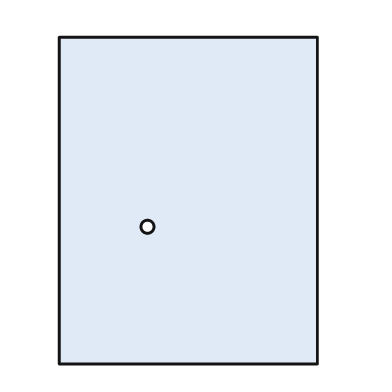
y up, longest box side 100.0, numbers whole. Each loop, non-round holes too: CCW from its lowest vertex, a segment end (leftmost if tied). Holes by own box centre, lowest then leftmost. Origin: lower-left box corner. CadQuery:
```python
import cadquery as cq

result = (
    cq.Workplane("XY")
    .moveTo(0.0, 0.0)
    .lineTo(79.0, 0.0)
    .lineTo(79.0, 100.0)
    .lineTo(0.0, 100.0)
    .close()
    .moveTo(27.0, 42.0)
    .circle(2.0)
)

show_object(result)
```